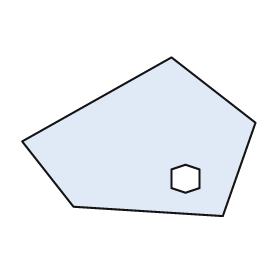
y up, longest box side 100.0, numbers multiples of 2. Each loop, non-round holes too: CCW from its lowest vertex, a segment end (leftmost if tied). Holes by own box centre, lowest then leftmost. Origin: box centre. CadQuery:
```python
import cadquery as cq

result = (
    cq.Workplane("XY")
    .moveTo(36.0, -34.0)
    .lineTo(50.0, 6.0)
    .lineTo(14.0, 34.0)
    .lineTo(-50.0, -2.0)
    .lineTo(-28.0, -30.0)
    .close()
    .moveTo(20.0, -24.0)
    .lineTo(26.0, -22.0)
    .lineTo(26.0, -14.0)
    .lineTo(20.0, -12.0)
    .lineTo(14.0, -14.0)
    .lineTo(14.0, -22.0)
    .close()
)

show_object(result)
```